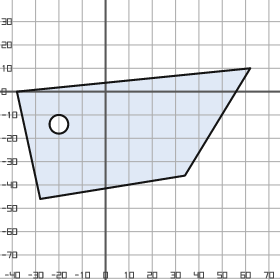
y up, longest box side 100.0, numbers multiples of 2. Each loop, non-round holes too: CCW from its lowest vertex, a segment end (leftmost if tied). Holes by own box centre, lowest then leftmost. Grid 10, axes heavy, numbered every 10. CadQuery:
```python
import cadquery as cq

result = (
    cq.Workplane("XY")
    .moveTo(-28.0, -46.0)
    .lineTo(34.0, -36.0)
    .lineTo(62.0, 10.0)
    .lineTo(-38.0, 0.0)
    .close()
    .moveTo(-20.0, -14.0)
    .circle(4.0)
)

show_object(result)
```